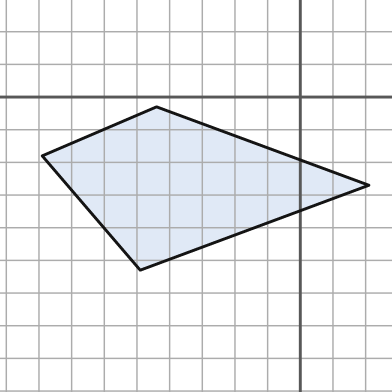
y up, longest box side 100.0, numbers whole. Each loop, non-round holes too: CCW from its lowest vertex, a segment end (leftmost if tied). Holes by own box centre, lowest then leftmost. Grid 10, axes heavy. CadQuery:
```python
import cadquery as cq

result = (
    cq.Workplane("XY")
    .moveTo(-49.0, -53.0)
    .lineTo(21.0, -27.0)
    .lineTo(-44.0, -3.0)
    .lineTo(-79.0, -18.0)
    .close()
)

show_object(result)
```